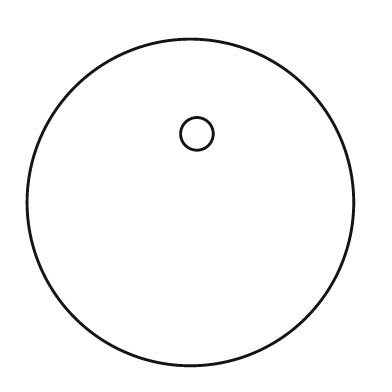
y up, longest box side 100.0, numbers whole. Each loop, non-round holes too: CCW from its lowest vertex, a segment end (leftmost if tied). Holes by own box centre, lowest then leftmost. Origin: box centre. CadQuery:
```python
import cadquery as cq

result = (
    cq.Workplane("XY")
    .moveTo(0.0, 0.0)
    .circle(50.0)
    .moveTo(2.0, 21.0)
    .circle(5.0)
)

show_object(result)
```